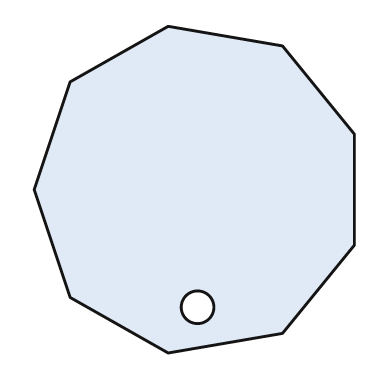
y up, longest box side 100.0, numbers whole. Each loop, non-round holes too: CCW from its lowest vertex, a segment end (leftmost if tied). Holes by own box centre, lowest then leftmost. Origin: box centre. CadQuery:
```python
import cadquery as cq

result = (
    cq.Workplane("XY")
    .moveTo(-8.0, -50.0)
    .lineTo(27.0, -44.0)
    .lineTo(49.0, -17.0)
    .lineTo(49.0, 17.0)
    .lineTo(27.0, 44.0)
    .lineTo(-8.0, 50.0)
    .lineTo(-38.0, 33.0)
    .lineTo(-49.0, 0.0)
    .lineTo(-38.0, -33.0)
    .close()
    .moveTo(1.0, -36.0)
    .circle(5.0)
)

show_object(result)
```